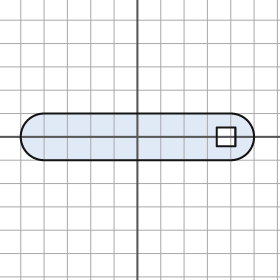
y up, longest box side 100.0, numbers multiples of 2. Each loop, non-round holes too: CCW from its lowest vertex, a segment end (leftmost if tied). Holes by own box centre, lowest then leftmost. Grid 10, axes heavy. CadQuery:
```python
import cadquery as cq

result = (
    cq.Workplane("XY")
    .moveTo(-40.0, -10.0)
    .lineTo(40.0, -10.0)
    .threePointArc((50.0, 0.0), (40.0, 10.0))
    .lineTo(-40.0, 10.0)
    .threePointArc((-50.0, 0.0), (-40.0, -10.0))
    .close()
    .moveTo(34.0, -4.0)
    .lineTo(42.0, -4.0)
    .lineTo(42.0, 4.0)
    .lineTo(34.0, 4.0)
    .close()
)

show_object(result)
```